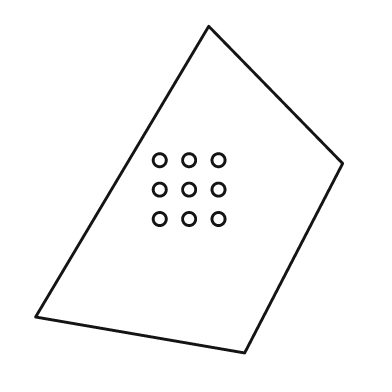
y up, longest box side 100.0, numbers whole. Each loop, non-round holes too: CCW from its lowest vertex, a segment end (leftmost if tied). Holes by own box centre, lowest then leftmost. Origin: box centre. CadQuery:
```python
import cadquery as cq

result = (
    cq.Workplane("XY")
    .moveTo(17.0, -50.0)
    .lineTo(47.0, 8.0)
    .lineTo(6.0, 50.0)
    .lineTo(-47.0, -39.0)
    .close()
    .moveTo(-9.0, -9.0)
    .circle(2.0)
    .moveTo(0.0, -9.0)
    .circle(2.0)
    .moveTo(9.0, -9.0)
    .circle(2.0)
    .moveTo(-9.0, 0.0)
    .circle(2.0)
    .moveTo(0.0, 0.0)
    .circle(2.0)
    .moveTo(9.0, 0.0)
    .circle(2.0)
    .moveTo(-9.0, 9.0)
    .circle(2.0)
    .moveTo(0.0, 9.0)
    .circle(2.0)
    .moveTo(9.0, 9.0)
    .circle(2.0)
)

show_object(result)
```